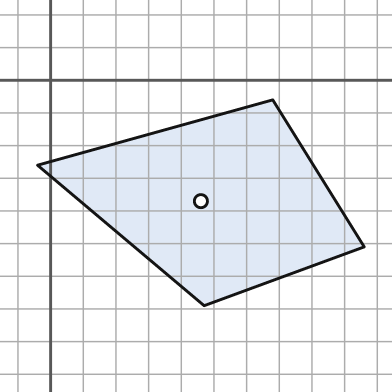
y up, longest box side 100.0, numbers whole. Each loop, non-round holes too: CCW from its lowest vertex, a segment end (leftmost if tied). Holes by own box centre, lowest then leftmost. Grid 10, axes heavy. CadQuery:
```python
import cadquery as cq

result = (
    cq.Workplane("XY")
    .moveTo(47.0, -69.0)
    .lineTo(96.0, -51.0)
    .lineTo(68.0, -6.0)
    .lineTo(-4.0, -26.0)
    .close()
    .moveTo(46.0, -37.0)
    .circle(2.0)
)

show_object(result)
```